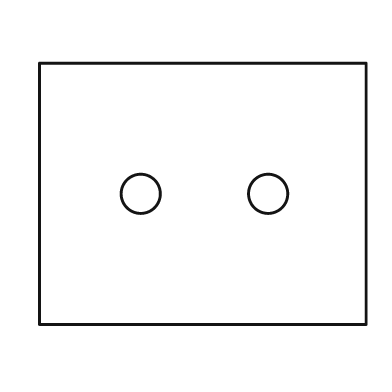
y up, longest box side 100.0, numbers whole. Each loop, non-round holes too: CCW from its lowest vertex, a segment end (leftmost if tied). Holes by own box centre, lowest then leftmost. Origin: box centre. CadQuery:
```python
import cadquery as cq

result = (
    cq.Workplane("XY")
    .moveTo(-50.0, -40.0)
    .lineTo(50.0, -40.0)
    .lineTo(50.0, 40.0)
    .lineTo(-50.0, 40.0)
    .close()
    .moveTo(-19.0, 0.0)
    .circle(6.0)
    .moveTo(20.0, 0.0)
    .circle(6.0)
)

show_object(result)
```